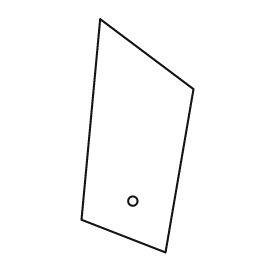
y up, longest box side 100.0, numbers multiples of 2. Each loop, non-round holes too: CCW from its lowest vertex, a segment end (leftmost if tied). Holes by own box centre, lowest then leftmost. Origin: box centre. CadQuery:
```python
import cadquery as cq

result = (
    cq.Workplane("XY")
    .moveTo(12.0, -50.0)
    .lineTo(24.0, 20.0)
    .lineTo(-16.0, 50.0)
    .lineTo(-24.0, -36.0)
    .close()
    .moveTo(-2.0, -28.0)
    .circle(2.0)
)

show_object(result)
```